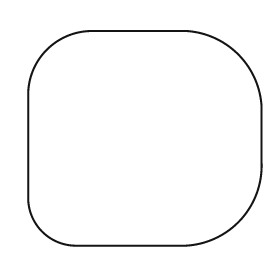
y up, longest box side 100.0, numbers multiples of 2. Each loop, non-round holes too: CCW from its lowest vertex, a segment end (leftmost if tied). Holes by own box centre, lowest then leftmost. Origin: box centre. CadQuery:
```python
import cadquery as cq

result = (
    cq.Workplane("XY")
    .moveTo(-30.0, -46.0)
    .lineTo(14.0, -46.0)
    .threePointArc((40.0, -36.0), (50.0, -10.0))
    .lineTo(50.0, 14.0)
    .threePointArc((40.0, 36.0), (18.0, 46.0))
    .lineTo(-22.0, 46.0)
    .threePointArc((-42.0, 38.0), (-50.0, 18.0))
    .lineTo(-50.0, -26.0)
    .threePointArc((-44.0, -40.0), (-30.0, -46.0))
    .close()
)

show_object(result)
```